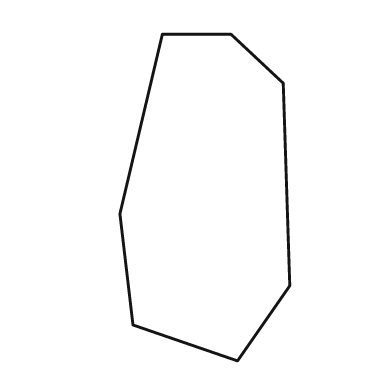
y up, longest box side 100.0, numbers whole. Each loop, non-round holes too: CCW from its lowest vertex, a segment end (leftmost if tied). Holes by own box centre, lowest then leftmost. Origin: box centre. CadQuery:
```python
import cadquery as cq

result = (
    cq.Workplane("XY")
    .moveTo(10.0, -50.0)
    .lineTo(26.0, -27.0)
    .lineTo(24.0, 35.0)
    .lineTo(8.0, 50.0)
    .lineTo(-13.0, 50.0)
    .lineTo(-26.0, -5.0)
    .lineTo(-22.0, -39.0)
    .close()
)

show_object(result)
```